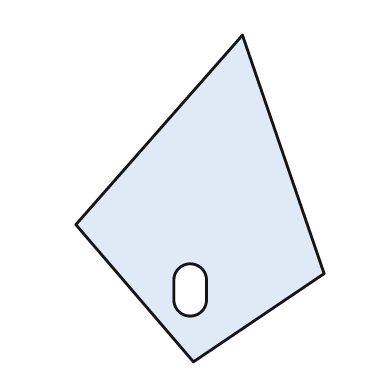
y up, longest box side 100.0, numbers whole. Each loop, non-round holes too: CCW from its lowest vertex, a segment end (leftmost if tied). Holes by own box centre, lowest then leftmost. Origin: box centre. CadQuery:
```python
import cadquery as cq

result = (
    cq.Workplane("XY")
    .moveTo(-2.0, -50.0)
    .lineTo(38.0, -23.0)
    .lineTo(13.0, 50.0)
    .lineTo(-38.0, -8.0)
    .close()
    .moveTo(-8.0, -31.0)
    .threePointArc((-3.0, -36.0), (2.0, -31.0))
    .lineTo(2.0, -25.0)
    .threePointArc((-3.0, -20.0), (-8.0, -25.0))
    .close()
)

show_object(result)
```